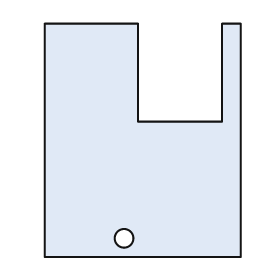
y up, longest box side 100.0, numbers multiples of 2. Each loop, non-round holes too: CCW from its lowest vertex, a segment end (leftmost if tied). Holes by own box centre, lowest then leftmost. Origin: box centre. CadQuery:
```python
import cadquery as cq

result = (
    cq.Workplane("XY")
    .moveTo(-42.0, -50.0)
    .lineTo(42.0, -50.0)
    .lineTo(42.0, 50.0)
    .lineTo(34.0, 50.0)
    .lineTo(34.0, 8.0)
    .lineTo(-2.0, 8.0)
    .lineTo(-2.0, 50.0)
    .lineTo(-42.0, 50.0)
    .close()
    .moveTo(-8.0, -42.0)
    .circle(4.0)
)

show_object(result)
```